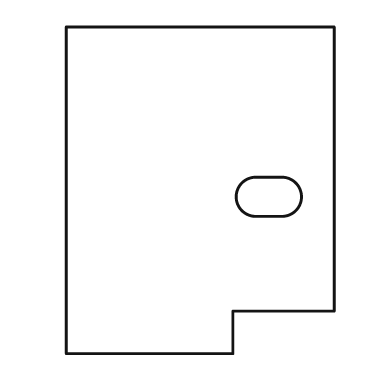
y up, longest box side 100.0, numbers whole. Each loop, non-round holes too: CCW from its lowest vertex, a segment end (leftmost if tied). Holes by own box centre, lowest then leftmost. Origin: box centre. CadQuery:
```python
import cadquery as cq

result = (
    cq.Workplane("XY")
    .moveTo(-41.0, -50.0)
    .lineTo(10.0, -50.0)
    .lineTo(10.0, -37.0)
    .lineTo(41.0, -37.0)
    .lineTo(41.0, 50.0)
    .lineTo(-41.0, 50.0)
    .close()
    .moveTo(17.0, -8.0)
    .lineTo(25.0, -8.0)
    .threePointArc((31.0, -2.0), (25.0, 4.0))
    .lineTo(17.0, 4.0)
    .threePointArc((11.0, -2.0), (17.0, -8.0))
    .close()
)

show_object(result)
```